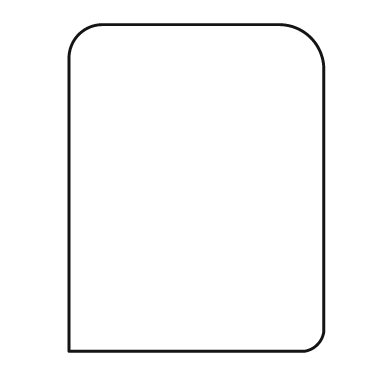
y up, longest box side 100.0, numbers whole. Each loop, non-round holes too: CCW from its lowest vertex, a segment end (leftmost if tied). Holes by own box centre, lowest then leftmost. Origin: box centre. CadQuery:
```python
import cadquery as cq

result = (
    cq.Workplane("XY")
    .moveTo(-39.0, -50.0)
    .lineTo(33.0, -50.0)
    .threePointArc((37.0, -48.0), (39.0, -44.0))
    .lineTo(39.0, 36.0)
    .threePointArc((35.0, 46.0), (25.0, 50.0))
    .lineTo(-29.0, 50.0)
    .threePointArc((-36.0, 47.0), (-39.0, 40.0))
    .close()
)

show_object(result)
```